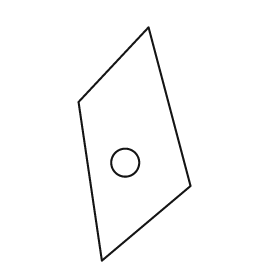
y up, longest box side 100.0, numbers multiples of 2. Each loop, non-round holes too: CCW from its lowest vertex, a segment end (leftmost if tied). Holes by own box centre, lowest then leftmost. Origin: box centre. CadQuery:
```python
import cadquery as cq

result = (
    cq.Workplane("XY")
    .moveTo(-14.0, -50.0)
    .lineTo(24.0, -18.0)
    .lineTo(6.0, 50.0)
    .lineTo(-24.0, 18.0)
    .close()
    .moveTo(-4.0, -8.0)
    .circle(6.0)
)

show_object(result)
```